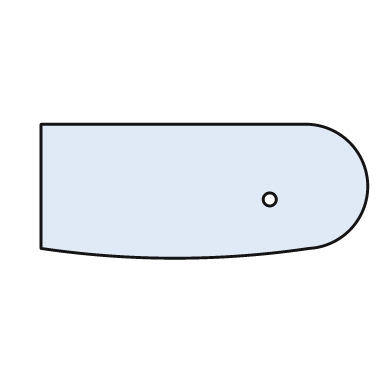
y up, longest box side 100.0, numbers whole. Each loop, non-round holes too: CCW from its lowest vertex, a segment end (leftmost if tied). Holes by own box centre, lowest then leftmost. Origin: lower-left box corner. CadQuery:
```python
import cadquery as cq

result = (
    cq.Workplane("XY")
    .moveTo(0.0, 3.0)
    .threePointArc((41.0, 0.0), (82.0, 3.0))
    .threePointArc((100.0, 22.0), (82.0, 41.0))
    .lineTo(0.0, 41.0)
    .close()
    .moveTo(70.0, 18.0)
    .circle(2.0)
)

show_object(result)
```